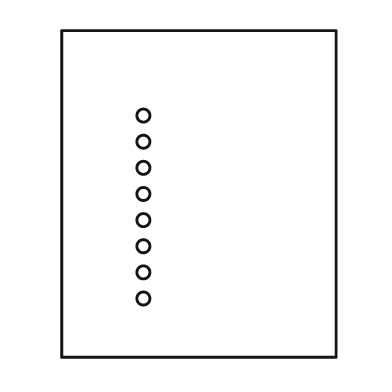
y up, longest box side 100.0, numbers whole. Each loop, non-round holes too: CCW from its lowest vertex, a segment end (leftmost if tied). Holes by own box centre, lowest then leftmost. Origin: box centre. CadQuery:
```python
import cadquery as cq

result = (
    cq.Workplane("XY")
    .moveTo(-42.0, -50.0)
    .lineTo(42.0, -50.0)
    .lineTo(42.0, 50.0)
    .lineTo(-42.0, 50.0)
    .close()
    .moveTo(-17.0, -32.0)
    .circle(2.0)
    .moveTo(-17.0, -24.0)
    .circle(2.0)
    .moveTo(-17.0, -16.0)
    .circle(2.0)
    .moveTo(-17.0, -8.0)
    .circle(2.0)
    .moveTo(-17.0, 0.0)
    .circle(2.0)
    .moveTo(-17.0, 8.0)
    .circle(2.0)
    .moveTo(-17.0, 16.0)
    .circle(2.0)
    .moveTo(-17.0, 24.0)
    .circle(2.0)
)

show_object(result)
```